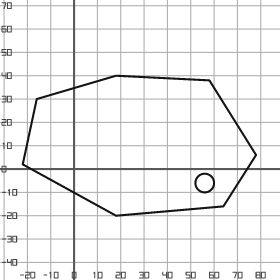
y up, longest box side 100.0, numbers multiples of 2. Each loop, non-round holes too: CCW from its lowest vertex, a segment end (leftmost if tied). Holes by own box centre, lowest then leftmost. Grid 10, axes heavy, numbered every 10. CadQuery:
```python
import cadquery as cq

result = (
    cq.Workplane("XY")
    .moveTo(18.0, -20.0)
    .lineTo(64.0, -16.0)
    .lineTo(78.0, 6.0)
    .lineTo(58.0, 38.0)
    .lineTo(18.0, 40.0)
    .lineTo(-16.0, 30.0)
    .lineTo(-22.0, 2.0)
    .close()
    .moveTo(56.0, -6.0)
    .circle(4.0)
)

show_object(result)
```